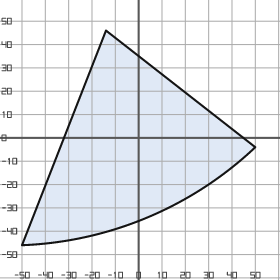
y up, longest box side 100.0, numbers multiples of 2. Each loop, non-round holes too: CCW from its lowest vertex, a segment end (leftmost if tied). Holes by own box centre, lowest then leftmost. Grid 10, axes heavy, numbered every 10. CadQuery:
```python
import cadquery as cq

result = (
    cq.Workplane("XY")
    .moveTo(-50.0, -46.0)
    .threePointArc((4.0, -34.0), (50.0, -4.0))
    .lineTo(-14.0, 46.0)
    .close()
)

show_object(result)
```